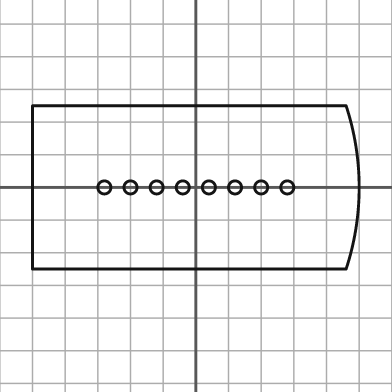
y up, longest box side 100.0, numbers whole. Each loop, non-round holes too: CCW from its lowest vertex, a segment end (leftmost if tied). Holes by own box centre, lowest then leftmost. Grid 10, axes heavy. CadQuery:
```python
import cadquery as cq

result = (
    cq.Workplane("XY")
    .moveTo(-50.0, -25.0)
    .lineTo(46.0, -25.0)
    .threePointArc((50.0, 0.0), (46.0, 25.0))
    .lineTo(-50.0, 25.0)
    .close()
    .moveTo(-28.0, 0.0)
    .circle(2.0)
    .moveTo(-20.0, 0.0)
    .circle(2.0)
    .moveTo(-12.0, 0.0)
    .circle(2.0)
    .moveTo(-4.0, 0.0)
    .circle(2.0)
    .moveTo(4.0, 0.0)
    .circle(2.0)
    .moveTo(12.0, 0.0)
    .circle(2.0)
    .moveTo(20.0, 0.0)
    .circle(2.0)
    .moveTo(28.0, 0.0)
    .circle(2.0)
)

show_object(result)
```